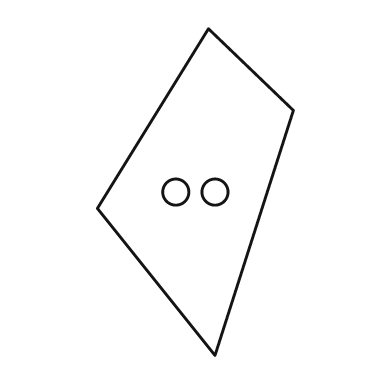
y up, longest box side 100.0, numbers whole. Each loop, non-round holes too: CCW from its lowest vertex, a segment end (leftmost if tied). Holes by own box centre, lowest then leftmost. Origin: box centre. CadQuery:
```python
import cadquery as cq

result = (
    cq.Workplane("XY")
    .moveTo(6.0, -50.0)
    .lineTo(30.0, 25.0)
    .lineTo(4.0, 50.0)
    .lineTo(-30.0, -5.0)
    .close()
    .moveTo(-6.0, 0.0)
    .circle(4.0)
    .moveTo(6.0, 0.0)
    .circle(4.0)
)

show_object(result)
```